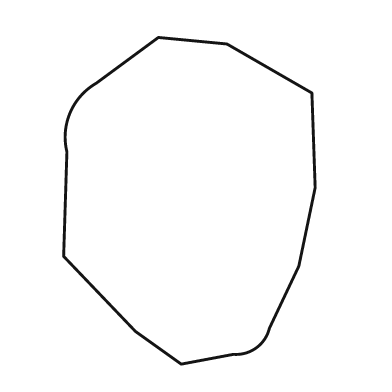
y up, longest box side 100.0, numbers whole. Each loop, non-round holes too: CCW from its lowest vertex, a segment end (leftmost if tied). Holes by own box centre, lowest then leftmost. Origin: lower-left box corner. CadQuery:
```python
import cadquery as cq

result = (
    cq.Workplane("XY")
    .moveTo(36.0, 0.0)
    .lineTo(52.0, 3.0)
    .threePointArc((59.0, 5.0), (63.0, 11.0))
    .lineTo(72.0, 30.0)
    .lineTo(77.0, 54.0)
    .lineTo(76.0, 83.0)
    .lineTo(50.0, 98.0)
    .lineTo(29.0, 100.0)
    .lineTo(10.0, 86.0)
    .threePointArc((2.0, 77.0), (1.0, 65.0))
    .lineTo(0.0, 33.0)
    .lineTo(22.0, 10.0)
    .close()
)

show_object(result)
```